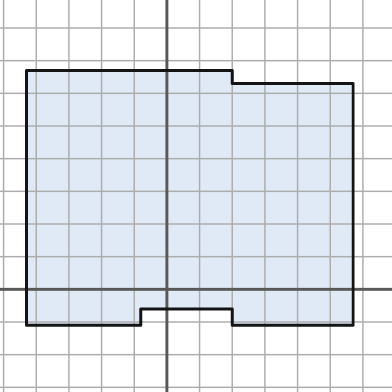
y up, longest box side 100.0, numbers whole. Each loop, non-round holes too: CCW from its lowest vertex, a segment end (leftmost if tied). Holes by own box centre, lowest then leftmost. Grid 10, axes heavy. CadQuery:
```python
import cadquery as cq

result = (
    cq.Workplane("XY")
    .moveTo(-43.0, -11.0)
    .lineTo(-8.0, -11.0)
    .lineTo(-8.0, -6.0)
    .lineTo(20.0, -6.0)
    .lineTo(20.0, -11.0)
    .lineTo(57.0, -11.0)
    .lineTo(57.0, 63.0)
    .lineTo(20.0, 63.0)
    .lineTo(20.0, 67.0)
    .lineTo(-43.0, 67.0)
    .close()
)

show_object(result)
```